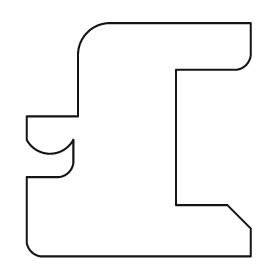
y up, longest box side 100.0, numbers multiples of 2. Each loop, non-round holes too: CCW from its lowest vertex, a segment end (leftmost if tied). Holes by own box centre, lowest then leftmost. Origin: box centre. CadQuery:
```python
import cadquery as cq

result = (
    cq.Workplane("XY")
    .moveTo(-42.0, -50.0)
    .lineTo(48.0, -50.0)
    .lineTo(48.0, -38.0)
    .lineTo(38.0, -28.0)
    .lineTo(16.0, -28.0)
    .lineTo(16.0, 30.0)
    .lineTo(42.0, 30.0)
    .threePointArc((46.0, 32.0), (48.0, 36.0))
    .lineTo(48.0, 50.0)
    .lineTo(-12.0, 50.0)
    .threePointArc((-22.0, 46.0), (-26.0, 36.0))
    .lineTo(-26.0, 10.0)
    .lineTo(-48.0, 10.0)
    .lineTo(-48.0, 0.0)
    .threePointArc((-38.0, -6.0), (-28.0, 0.0))
    .lineTo(-28.0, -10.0)
    .threePointArc((-30.0, -14.0), (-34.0, -16.0))
    .lineTo(-48.0, -16.0)
    .lineTo(-48.0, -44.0)
    .threePointArc((-46.0, -48.0), (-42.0, -50.0))
    .close()
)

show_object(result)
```